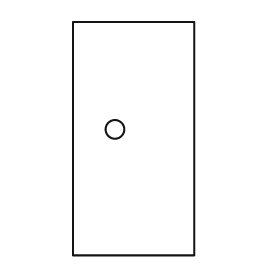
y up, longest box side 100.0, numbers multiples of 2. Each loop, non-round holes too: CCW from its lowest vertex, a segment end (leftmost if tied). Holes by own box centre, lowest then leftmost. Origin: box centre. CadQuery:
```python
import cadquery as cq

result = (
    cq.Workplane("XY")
    .moveTo(-26.0, -50.0)
    .lineTo(26.0, -50.0)
    .lineTo(26.0, 50.0)
    .lineTo(-26.0, 50.0)
    .close()
    .moveTo(-8.0, 4.0)
    .circle(4.0)
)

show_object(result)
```